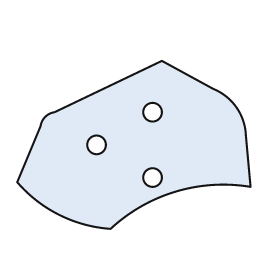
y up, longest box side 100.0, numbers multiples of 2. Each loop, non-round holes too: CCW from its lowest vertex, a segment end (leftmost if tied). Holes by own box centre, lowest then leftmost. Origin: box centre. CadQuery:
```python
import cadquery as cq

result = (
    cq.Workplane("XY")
    .moveTo(-10.0, -36.0)
    .threePointArc((18.0, -20.0), (50.0, -18.0))
    .lineTo(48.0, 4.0)
    .threePointArc((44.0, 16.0), (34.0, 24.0))
    .lineTo(12.0, 36.0)
    .lineTo(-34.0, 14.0)
    .threePointArc((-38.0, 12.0), (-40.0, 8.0))
    .lineTo(-50.0, -16.0)
    .threePointArc((-32.0, -30.0), (-10.0, -36.0))
    .close()
    .moveTo(8.0, -14.0)
    .circle(4.0)
    .moveTo(-16.0, 0.0)
    .circle(4.0)
    .moveTo(8.0, 14.0)
    .circle(4.0)
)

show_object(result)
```